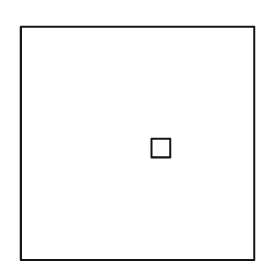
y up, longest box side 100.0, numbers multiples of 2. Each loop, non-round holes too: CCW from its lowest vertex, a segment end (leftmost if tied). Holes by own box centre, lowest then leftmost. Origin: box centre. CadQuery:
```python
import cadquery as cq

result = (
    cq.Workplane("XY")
    .moveTo(-50.0, -50.0)
    .lineTo(50.0, -50.0)
    .lineTo(50.0, 50.0)
    .lineTo(-50.0, 50.0)
    .close()
    .moveTo(6.0, -6.0)
    .lineTo(14.0, -6.0)
    .lineTo(14.0, 2.0)
    .lineTo(6.0, 2.0)
    .close()
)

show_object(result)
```